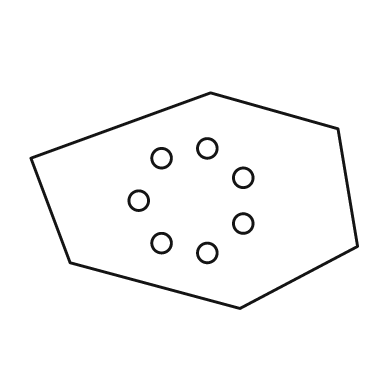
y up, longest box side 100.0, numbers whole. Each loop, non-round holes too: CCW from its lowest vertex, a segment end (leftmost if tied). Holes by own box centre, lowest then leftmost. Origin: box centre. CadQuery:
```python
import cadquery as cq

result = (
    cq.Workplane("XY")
    .moveTo(14.0, -33.0)
    .lineTo(50.0, -14.0)
    .lineTo(44.0, 22.0)
    .lineTo(5.0, 33.0)
    .lineTo(-50.0, 13.0)
    .lineTo(-38.0, -19.0)
    .close()
    .moveTo(4.0, -16.0)
    .circle(3.0)
    .moveTo(-10.0, -13.0)
    .circle(3.0)
    .moveTo(15.0, -7.0)
    .circle(3.0)
    .moveTo(-17.0, 0.0)
    .circle(3.0)
    .moveTo(15.0, 7.0)
    .circle(3.0)
    .moveTo(-10.0, 13.0)
    .circle(3.0)
    .moveTo(4.0, 16.0)
    .circle(3.0)
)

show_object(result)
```